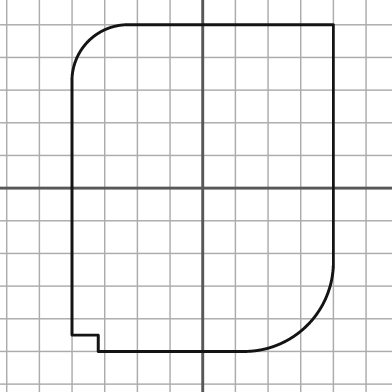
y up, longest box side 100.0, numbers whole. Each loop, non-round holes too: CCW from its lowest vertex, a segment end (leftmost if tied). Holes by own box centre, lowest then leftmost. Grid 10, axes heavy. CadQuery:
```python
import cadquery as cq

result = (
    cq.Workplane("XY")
    .moveTo(-32.0, -50.0)
    .lineTo(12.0, -50.0)
    .threePointArc((32.0, -42.0), (40.0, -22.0))
    .lineTo(40.0, 50.0)
    .lineTo(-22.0, 50.0)
    .threePointArc((-35.0, 45.0), (-40.0, 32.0))
    .lineTo(-40.0, -45.0)
    .lineTo(-32.0, -45.0)
    .close()
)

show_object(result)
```